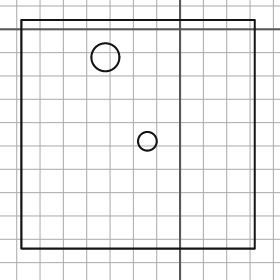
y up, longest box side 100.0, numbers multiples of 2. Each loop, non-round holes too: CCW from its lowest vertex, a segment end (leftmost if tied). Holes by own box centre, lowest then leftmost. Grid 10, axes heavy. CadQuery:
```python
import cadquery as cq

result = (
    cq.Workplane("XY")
    .moveTo(-68.0, -94.0)
    .lineTo(32.0, -94.0)
    .lineTo(32.0, 4.0)
    .lineTo(-68.0, 4.0)
    .close()
    .moveTo(-14.0, -48.0)
    .circle(4.0)
    .moveTo(-32.0, -12.0)
    .circle(6.0)
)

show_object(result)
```